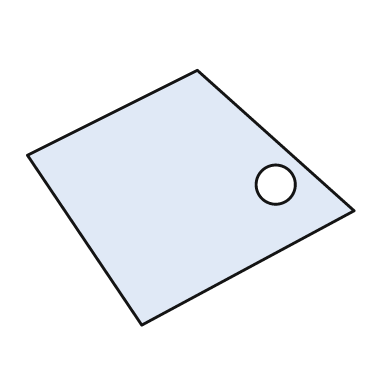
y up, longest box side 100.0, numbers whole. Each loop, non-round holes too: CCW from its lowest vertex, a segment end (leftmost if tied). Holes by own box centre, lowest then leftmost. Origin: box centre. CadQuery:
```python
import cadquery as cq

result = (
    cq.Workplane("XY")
    .moveTo(-15.0, -39.0)
    .lineTo(50.0, -4.0)
    .lineTo(2.0, 39.0)
    .lineTo(-50.0, 13.0)
    .close()
    .moveTo(26.0, 4.0)
    .circle(6.0)
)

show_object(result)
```